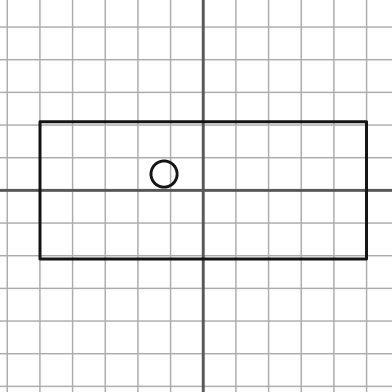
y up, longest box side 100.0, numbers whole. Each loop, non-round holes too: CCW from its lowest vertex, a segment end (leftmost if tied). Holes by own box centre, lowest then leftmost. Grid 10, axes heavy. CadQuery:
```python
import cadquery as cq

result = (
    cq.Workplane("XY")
    .moveTo(-50.0, -21.0)
    .lineTo(50.0, -21.0)
    .lineTo(50.0, 21.0)
    .lineTo(-50.0, 21.0)
    .close()
    .moveTo(-12.0, 5.0)
    .circle(4.0)
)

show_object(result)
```